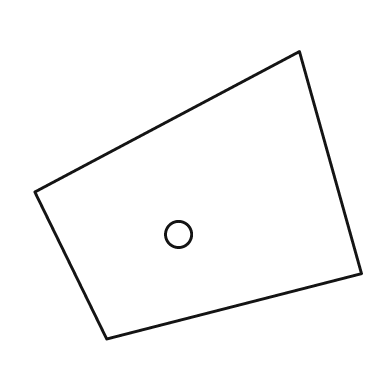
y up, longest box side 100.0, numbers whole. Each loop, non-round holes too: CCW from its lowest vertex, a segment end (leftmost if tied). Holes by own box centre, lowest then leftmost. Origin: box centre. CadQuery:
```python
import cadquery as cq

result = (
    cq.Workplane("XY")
    .moveTo(-28.0, -44.0)
    .lineTo(50.0, -24.0)
    .lineTo(31.0, 44.0)
    .lineTo(-50.0, 1.0)
    .close()
    .moveTo(-6.0, -12.0)
    .circle(4.0)
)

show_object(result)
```